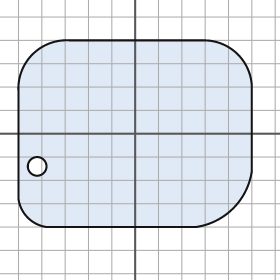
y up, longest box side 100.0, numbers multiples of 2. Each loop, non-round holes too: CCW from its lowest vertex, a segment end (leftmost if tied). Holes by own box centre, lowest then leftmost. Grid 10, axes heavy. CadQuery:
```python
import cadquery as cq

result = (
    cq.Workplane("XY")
    .moveTo(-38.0, -40.0)
    .lineTo(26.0, -40.0)
    .threePointArc((42.0, -32.0), (50.0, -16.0))
    .lineTo(50.0, 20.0)
    .threePointArc((44.0, 34.0), (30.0, 40.0))
    .lineTo(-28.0, 40.0)
    .threePointArc((-44.0, 34.0), (-50.0, 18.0))
    .lineTo(-50.0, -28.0)
    .threePointArc((-46.0, -36.0), (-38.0, -40.0))
    .close()
    .moveTo(-42.0, -14.0)
    .circle(4.0)
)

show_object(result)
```